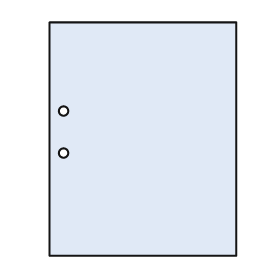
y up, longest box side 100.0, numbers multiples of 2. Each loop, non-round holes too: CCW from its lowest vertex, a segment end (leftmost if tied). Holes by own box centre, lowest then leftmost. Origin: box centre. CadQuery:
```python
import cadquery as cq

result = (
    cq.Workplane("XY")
    .moveTo(-40.0, -50.0)
    .lineTo(40.0, -50.0)
    .lineTo(40.0, 50.0)
    .lineTo(-40.0, 50.0)
    .close()
    .moveTo(-34.0, -6.0)
    .circle(2.0)
    .moveTo(-34.0, 12.0)
    .circle(2.0)
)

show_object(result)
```